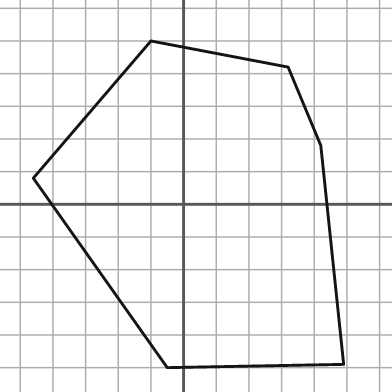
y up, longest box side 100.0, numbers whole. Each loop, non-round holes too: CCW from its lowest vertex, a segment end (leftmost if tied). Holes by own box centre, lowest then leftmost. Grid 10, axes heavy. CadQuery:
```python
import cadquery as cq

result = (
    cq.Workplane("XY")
    .moveTo(-5.0, -50.0)
    .lineTo(49.0, -49.0)
    .lineTo(42.0, 18.0)
    .lineTo(32.0, 42.0)
    .lineTo(-10.0, 50.0)
    .lineTo(-46.0, 8.0)
    .close()
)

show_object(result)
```